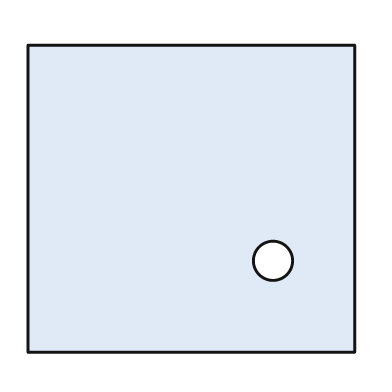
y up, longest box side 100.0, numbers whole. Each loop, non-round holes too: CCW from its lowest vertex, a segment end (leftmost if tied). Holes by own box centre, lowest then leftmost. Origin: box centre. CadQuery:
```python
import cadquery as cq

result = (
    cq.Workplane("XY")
    .moveTo(-50.0, -47.0)
    .lineTo(50.0, -47.0)
    .lineTo(50.0, 47.0)
    .lineTo(-50.0, 47.0)
    .close()
    .moveTo(25.0, -19.0)
    .circle(6.0)
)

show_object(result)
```